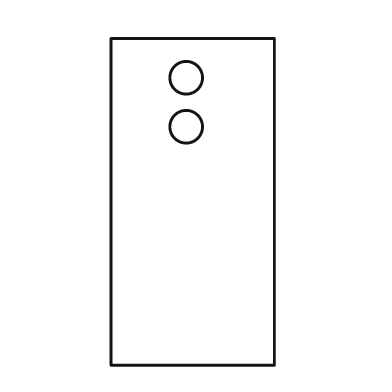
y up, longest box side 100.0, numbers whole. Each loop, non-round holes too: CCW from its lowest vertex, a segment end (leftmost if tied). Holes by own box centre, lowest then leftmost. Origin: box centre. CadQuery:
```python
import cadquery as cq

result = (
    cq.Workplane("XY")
    .moveTo(-25.0, -50.0)
    .lineTo(25.0, -50.0)
    .lineTo(25.0, 50.0)
    .lineTo(-25.0, 50.0)
    .close()
    .moveTo(-2.0, 23.0)
    .circle(5.0)
    .moveTo(-2.0, 38.0)
    .circle(5.0)
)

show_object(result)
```